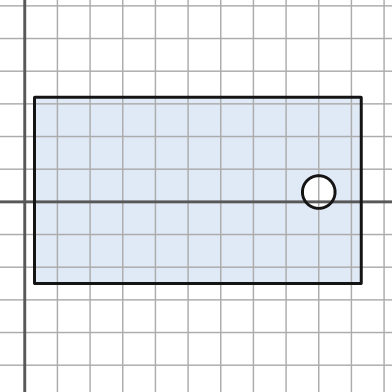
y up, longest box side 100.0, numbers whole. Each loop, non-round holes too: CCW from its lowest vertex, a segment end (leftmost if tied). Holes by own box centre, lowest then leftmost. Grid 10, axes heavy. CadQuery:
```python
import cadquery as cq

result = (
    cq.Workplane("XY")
    .moveTo(3.0, -25.0)
    .lineTo(103.0, -25.0)
    .lineTo(103.0, 32.0)
    .lineTo(3.0, 32.0)
    .close()
    .moveTo(90.0, 3.0)
    .circle(5.0)
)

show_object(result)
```